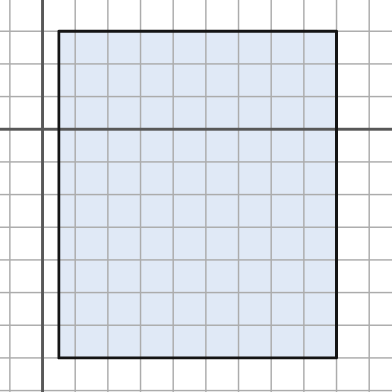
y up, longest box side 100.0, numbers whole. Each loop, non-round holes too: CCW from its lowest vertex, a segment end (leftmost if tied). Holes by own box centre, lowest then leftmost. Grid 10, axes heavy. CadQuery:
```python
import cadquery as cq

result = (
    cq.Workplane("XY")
    .moveTo(5.0, -70.0)
    .lineTo(90.0, -70.0)
    .lineTo(90.0, 30.0)
    .lineTo(5.0, 30.0)
    .close()
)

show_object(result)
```